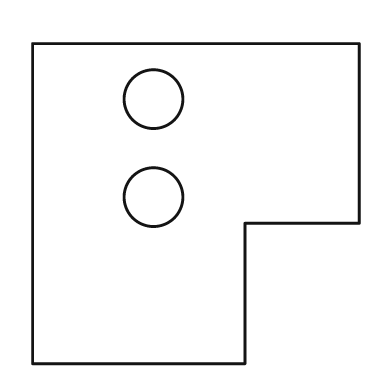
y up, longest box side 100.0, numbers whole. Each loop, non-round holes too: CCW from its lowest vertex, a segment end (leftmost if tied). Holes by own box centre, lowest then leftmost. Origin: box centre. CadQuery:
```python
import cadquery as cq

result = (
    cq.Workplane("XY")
    .moveTo(-50.0, -49.0)
    .lineTo(15.0, -49.0)
    .lineTo(15.0, -6.0)
    .lineTo(50.0, -6.0)
    .lineTo(50.0, 49.0)
    .lineTo(-50.0, 49.0)
    .close()
    .moveTo(-13.0, 2.0)
    .circle(9.0)
    .moveTo(-13.0, 32.0)
    .circle(9.0)
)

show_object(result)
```